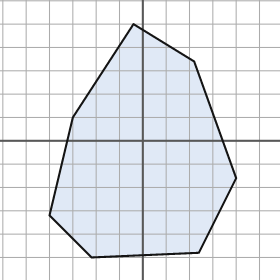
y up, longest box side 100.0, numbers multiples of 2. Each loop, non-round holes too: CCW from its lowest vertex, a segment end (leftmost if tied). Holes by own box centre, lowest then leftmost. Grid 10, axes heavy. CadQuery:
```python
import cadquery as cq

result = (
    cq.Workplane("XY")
    .moveTo(-22.0, -50.0)
    .lineTo(24.0, -48.0)
    .lineTo(40.0, -16.0)
    .lineTo(22.0, 34.0)
    .lineTo(-4.0, 50.0)
    .lineTo(-30.0, 10.0)
    .lineTo(-40.0, -32.0)
    .close()
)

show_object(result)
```